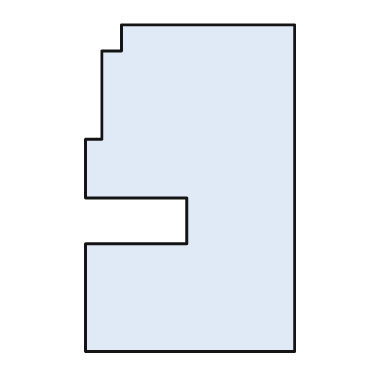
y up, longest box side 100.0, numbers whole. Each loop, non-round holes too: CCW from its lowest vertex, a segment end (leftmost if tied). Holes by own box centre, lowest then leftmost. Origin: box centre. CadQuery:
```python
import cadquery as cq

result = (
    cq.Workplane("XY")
    .moveTo(-32.0, -50.0)
    .lineTo(32.0, -50.0)
    .lineTo(32.0, 50.0)
    .lineTo(-21.0, 50.0)
    .lineTo(-21.0, 42.0)
    .lineTo(-27.0, 42.0)
    .lineTo(-27.0, 15.0)
    .lineTo(-32.0, 15.0)
    .lineTo(-32.0, -3.0)
    .lineTo(-1.0, -3.0)
    .lineTo(-1.0, -17.0)
    .lineTo(-32.0, -17.0)
    .close()
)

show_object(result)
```